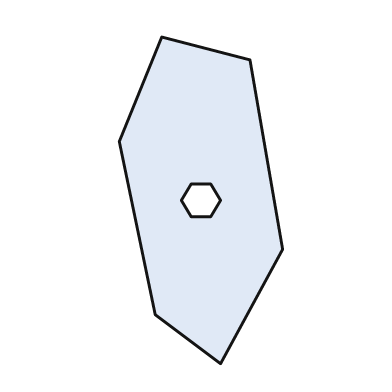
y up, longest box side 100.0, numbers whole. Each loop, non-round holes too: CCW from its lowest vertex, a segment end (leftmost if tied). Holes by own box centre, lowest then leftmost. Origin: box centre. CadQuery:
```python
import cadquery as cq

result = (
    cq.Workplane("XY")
    .moveTo(6.0, -50.0)
    .lineTo(25.0, -15.0)
    .lineTo(15.0, 43.0)
    .lineTo(-12.0, 50.0)
    .lineTo(-25.0, 18.0)
    .lineTo(-14.0, -35.0)
    .close()
    .moveTo(-3.0, -5.0)
    .lineTo(3.0, -5.0)
    .lineTo(6.0, 0.0)
    .lineTo(3.0, 5.0)
    .lineTo(-3.0, 5.0)
    .lineTo(-6.0, 0.0)
    .close()
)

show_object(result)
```